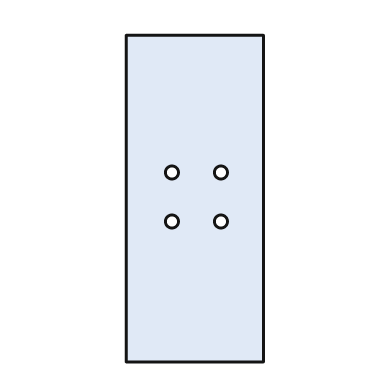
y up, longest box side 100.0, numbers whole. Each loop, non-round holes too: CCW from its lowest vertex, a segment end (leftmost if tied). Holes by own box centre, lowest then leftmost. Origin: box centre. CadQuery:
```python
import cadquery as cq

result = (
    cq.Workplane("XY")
    .moveTo(-21.0, -50.0)
    .lineTo(21.0, -50.0)
    .lineTo(21.0, 50.0)
    .lineTo(-21.0, 50.0)
    .close()
    .moveTo(-7.0, -7.0)
    .circle(2.0)
    .moveTo(8.0, -7.0)
    .circle(2.0)
    .moveTo(-7.0, 8.0)
    .circle(2.0)
    .moveTo(8.0, 8.0)
    .circle(2.0)
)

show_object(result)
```